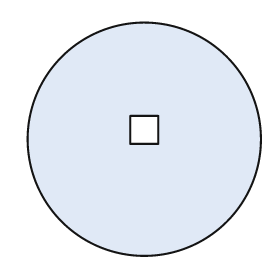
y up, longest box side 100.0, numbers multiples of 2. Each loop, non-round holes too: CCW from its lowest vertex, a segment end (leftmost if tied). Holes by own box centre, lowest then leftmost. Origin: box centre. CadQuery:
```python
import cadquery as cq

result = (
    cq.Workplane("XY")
    .moveTo(0.0, 0.0)
    .circle(50.0)
    .moveTo(-6.0, -2.0)
    .lineTo(6.0, -2.0)
    .lineTo(6.0, 10.0)
    .lineTo(-6.0, 10.0)
    .close()
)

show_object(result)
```